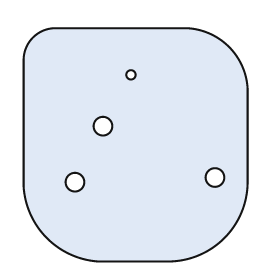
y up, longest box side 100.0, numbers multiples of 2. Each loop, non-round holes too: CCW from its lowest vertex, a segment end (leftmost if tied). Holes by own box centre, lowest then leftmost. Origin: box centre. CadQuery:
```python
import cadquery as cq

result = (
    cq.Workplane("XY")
    .moveTo(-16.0, -50.0)
    .lineTo(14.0, -50.0)
    .threePointArc((38.0, -40.0), (48.0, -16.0))
    .lineTo(48.0, 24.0)
    .threePointArc((40.0, 42.0), (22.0, 50.0))
    .lineTo(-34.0, 50.0)
    .threePointArc((-44.0, 46.0), (-48.0, 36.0))
    .lineTo(-48.0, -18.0)
    .threePointArc((-38.0, -40.0), (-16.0, -50.0))
    .close()
    .moveTo(-26.0, -16.0)
    .circle(4.0)
    .moveTo(34.0, -14.0)
    .circle(4.0)
    .moveTo(-14.0, 8.0)
    .circle(4.0)
    .moveTo(-2.0, 30.0)
    .circle(2.0)
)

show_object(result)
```